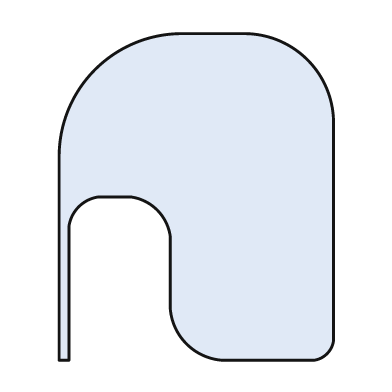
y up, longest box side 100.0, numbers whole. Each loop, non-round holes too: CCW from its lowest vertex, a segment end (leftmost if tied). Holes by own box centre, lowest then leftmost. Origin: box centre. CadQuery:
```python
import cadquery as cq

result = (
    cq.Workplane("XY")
    .moveTo(-42.0, -50.0)
    .lineTo(-39.0, -50.0)
    .lineTo(-39.0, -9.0)
    .threePointArc((-36.0, -3.0), (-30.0, 0.0))
    .lineTo(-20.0, 0.0)
    .threePointArc((-12.0, -4.0), (-8.0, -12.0))
    .lineTo(-8.0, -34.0)
    .threePointArc((-3.0, -45.0), (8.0, -50.0))
    .lineTo(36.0, -50.0)
    .threePointArc((40.0, -48.0), (42.0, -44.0))
    .lineTo(42.0, 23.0)
    .threePointArc((34.0, 42.0), (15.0, 50.0))
    .lineTo(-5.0, 50.0)
    .threePointArc((-31.0, 39.0), (-42.0, 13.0))
    .close()
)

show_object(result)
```